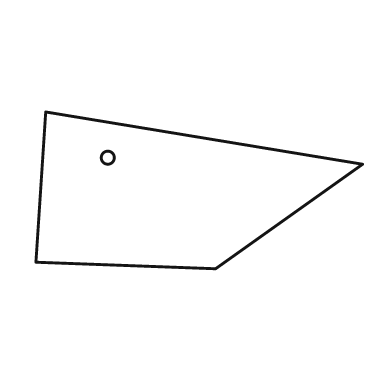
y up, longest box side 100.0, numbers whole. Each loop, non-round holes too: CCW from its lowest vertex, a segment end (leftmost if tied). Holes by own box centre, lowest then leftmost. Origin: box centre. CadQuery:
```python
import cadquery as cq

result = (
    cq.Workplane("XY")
    .moveTo(5.0, -24.0)
    .lineTo(50.0, 8.0)
    .lineTo(-47.0, 24.0)
    .lineTo(-50.0, -22.0)
    .close()
    .moveTo(-28.0, 10.0)
    .circle(2.0)
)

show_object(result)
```